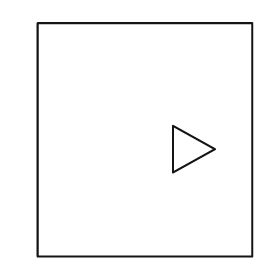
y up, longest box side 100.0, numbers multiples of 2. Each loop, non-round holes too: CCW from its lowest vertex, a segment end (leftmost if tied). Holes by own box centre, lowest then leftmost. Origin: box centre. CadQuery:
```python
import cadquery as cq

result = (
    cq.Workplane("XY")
    .moveTo(-46.0, -50.0)
    .lineTo(46.0, -50.0)
    .lineTo(46.0, 50.0)
    .lineTo(-46.0, 50.0)
    .close()
    .moveTo(12.0, -14.0)
    .lineTo(30.0, -4.0)
    .lineTo(12.0, 6.0)
    .close()
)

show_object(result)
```